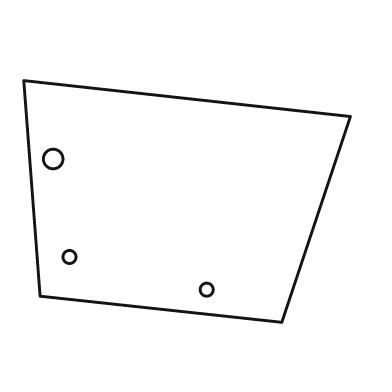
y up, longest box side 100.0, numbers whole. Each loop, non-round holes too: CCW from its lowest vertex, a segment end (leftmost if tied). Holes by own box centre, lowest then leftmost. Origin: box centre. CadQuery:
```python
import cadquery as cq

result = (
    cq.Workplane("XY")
    .moveTo(29.0, -37.0)
    .lineTo(50.0, 26.0)
    .lineTo(-50.0, 37.0)
    .lineTo(-45.0, -29.0)
    .close()
    .moveTo(6.0, -27.0)
    .circle(2.0)
    .moveTo(-36.0, -17.0)
    .circle(2.0)
    .moveTo(-41.0, 13.0)
    .circle(3.0)
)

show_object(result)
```